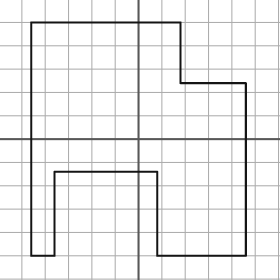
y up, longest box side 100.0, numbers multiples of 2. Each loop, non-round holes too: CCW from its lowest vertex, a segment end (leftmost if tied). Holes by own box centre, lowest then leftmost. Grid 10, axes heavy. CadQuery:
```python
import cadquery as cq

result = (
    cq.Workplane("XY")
    .moveTo(-46.0, -50.0)
    .lineTo(-36.0, -50.0)
    .lineTo(-36.0, -14.0)
    .lineTo(8.0, -14.0)
    .lineTo(8.0, -50.0)
    .lineTo(46.0, -50.0)
    .lineTo(46.0, 24.0)
    .lineTo(18.0, 24.0)
    .lineTo(18.0, 50.0)
    .lineTo(-46.0, 50.0)
    .close()
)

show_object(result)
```